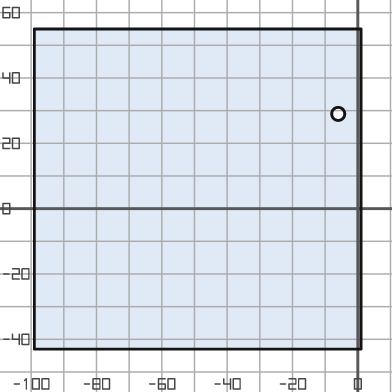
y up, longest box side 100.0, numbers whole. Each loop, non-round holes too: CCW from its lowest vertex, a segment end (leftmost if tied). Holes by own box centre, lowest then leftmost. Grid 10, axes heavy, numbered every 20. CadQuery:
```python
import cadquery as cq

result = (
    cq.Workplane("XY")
    .moveTo(-99.0, -43.0)
    .lineTo(1.0, -43.0)
    .lineTo(1.0, 55.0)
    .lineTo(-99.0, 55.0)
    .close()
    .moveTo(-6.0, 29.0)
    .circle(2.0)
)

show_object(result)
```